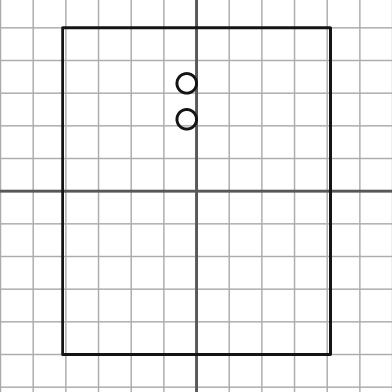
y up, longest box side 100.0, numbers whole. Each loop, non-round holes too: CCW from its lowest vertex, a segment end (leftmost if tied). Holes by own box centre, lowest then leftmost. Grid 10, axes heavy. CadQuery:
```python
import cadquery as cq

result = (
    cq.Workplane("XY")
    .moveTo(-41.0, -50.0)
    .lineTo(41.0, -50.0)
    .lineTo(41.0, 50.0)
    .lineTo(-41.0, 50.0)
    .close()
    .moveTo(-3.0, 22.0)
    .circle(3.0)
    .moveTo(-3.0, 33.0)
    .circle(3.0)
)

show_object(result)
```